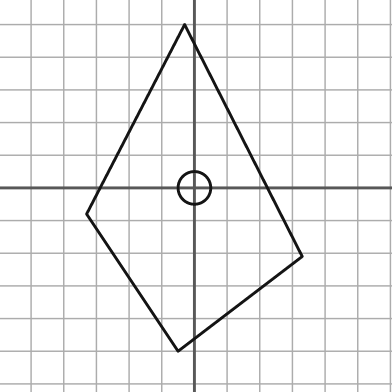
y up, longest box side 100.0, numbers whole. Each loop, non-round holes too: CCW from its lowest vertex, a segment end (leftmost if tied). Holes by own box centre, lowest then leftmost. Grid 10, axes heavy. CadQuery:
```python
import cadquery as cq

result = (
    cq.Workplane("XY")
    .moveTo(-5.0, -50.0)
    .lineTo(33.0, -21.0)
    .lineTo(-3.0, 50.0)
    .lineTo(-33.0, -8.0)
    .close()
    .moveTo(0.0, 0.0)
    .circle(5.0)
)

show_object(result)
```